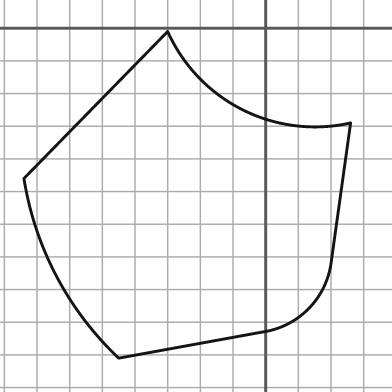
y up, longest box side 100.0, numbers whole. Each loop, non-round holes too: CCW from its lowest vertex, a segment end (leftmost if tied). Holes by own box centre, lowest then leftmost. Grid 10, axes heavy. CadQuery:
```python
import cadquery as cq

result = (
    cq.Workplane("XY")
    .moveTo(-45.0, -101.0)
    .lineTo(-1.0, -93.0)
    .threePointArc((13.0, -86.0), (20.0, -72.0))
    .lineTo(26.0, -29.0)
    .threePointArc((-7.0, -25.0), (-30.0, -1.0))
    .lineTo(-74.0, -46.0)
    .threePointArc((-64.0, -76.0), (-45.0, -101.0))
    .close()
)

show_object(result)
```